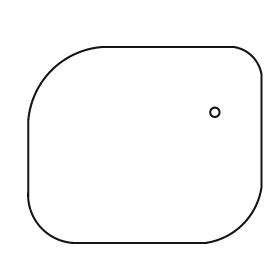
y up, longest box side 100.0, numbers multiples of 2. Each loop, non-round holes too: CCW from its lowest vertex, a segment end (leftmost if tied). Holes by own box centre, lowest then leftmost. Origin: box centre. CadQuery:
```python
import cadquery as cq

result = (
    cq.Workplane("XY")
    .moveTo(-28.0, -42.0)
    .lineTo(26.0, -42.0)
    .threePointArc((42.0, -34.0), (50.0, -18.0))
    .lineTo(50.0, 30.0)
    .threePointArc((46.0, 38.0), (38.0, 42.0))
    .lineTo(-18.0, 42.0)
    .threePointArc((-40.0, 32.0), (-50.0, 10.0))
    .lineTo(-50.0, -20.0)
    .threePointArc((-44.0, -36.0), (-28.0, -42.0))
    .close()
    .moveTo(30.0, 14.0)
    .circle(2.0)
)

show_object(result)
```